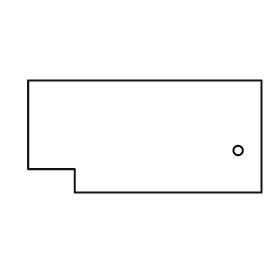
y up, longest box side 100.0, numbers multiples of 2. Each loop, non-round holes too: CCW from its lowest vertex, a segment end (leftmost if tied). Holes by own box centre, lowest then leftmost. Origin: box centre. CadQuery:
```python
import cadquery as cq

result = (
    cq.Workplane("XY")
    .moveTo(-30.0, -24.0)
    .lineTo(50.0, -24.0)
    .lineTo(50.0, 24.0)
    .lineTo(-50.0, 24.0)
    .lineTo(-50.0, -14.0)
    .lineTo(-30.0, -14.0)
    .close()
    .moveTo(40.0, -6.0)
    .circle(2.0)
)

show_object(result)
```